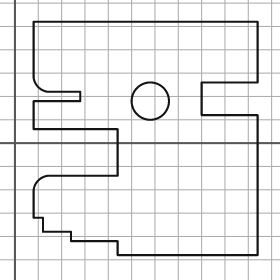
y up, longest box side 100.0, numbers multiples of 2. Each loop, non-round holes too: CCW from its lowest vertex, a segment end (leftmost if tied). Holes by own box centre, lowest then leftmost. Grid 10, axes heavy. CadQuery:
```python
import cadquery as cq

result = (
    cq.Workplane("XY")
    .moveTo(44.0, -48.0)
    .lineTo(104.0, -48.0)
    .lineTo(104.0, 12.0)
    .lineTo(80.0, 12.0)
    .lineTo(80.0, 26.0)
    .lineTo(104.0, 26.0)
    .lineTo(104.0, 52.0)
    .lineTo(8.0, 52.0)
    .lineTo(8.0, 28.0)
    .threePointArc((10.0, 24.0), (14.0, 22.0))
    .lineTo(28.0, 22.0)
    .lineTo(28.0, 18.0)
    .lineTo(8.0, 18.0)
    .lineTo(8.0, 6.0)
    .lineTo(44.0, 6.0)
    .lineTo(44.0, -14.0)
    .lineTo(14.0, -14.0)
    .threePointArc((10.0, -16.0), (8.0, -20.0))
    .lineTo(8.0, -32.0)
    .lineTo(12.0, -32.0)
    .lineTo(12.0, -38.0)
    .lineTo(24.0, -38.0)
    .lineTo(24.0, -42.0)
    .lineTo(44.0, -42.0)
    .close()
    .moveTo(58.0, 18.0)
    .circle(8.0)
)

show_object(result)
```